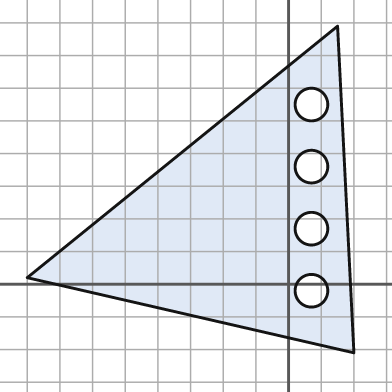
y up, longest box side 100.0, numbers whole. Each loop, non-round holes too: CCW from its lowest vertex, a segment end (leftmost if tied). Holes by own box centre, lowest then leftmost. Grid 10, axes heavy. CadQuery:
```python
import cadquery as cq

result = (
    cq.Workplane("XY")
    .moveTo(20.0, -21.0)
    .lineTo(15.0, 79.0)
    .lineTo(-80.0, 2.0)
    .close()
    .moveTo(7.0, -2.0)
    .circle(5.0)
    .moveTo(7.0, 17.0)
    .circle(5.0)
    .moveTo(7.0, 36.0)
    .circle(5.0)
    .moveTo(7.0, 55.0)
    .circle(5.0)
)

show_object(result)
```